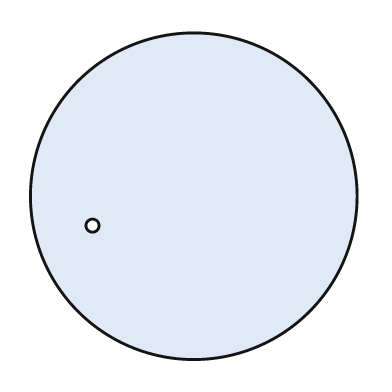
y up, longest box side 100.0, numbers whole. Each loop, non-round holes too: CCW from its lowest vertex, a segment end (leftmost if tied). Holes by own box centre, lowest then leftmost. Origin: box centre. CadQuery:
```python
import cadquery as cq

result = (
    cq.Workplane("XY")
    .moveTo(0.0, 0.0)
    .circle(50.0)
    .moveTo(-31.0, -9.0)
    .circle(2.0)
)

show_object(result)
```